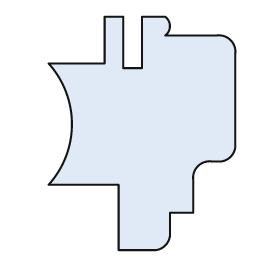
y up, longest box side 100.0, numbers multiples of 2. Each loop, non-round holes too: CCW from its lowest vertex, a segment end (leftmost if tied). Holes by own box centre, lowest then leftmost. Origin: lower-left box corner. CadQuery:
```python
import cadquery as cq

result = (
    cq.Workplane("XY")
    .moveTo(30.0, 0.0)
    .lineTo(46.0, 0.0)
    .threePointArc((50.0, 2.0), (52.0, 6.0))
    .lineTo(52.0, 16.0)
    .lineTo(62.0, 16.0)
    .lineTo(62.0, 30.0)
    .threePointArc((64.0, 36.0), (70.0, 38.0))
    .lineTo(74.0, 38.0)
    .threePointArc((78.0, 40.0), (80.0, 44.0))
    .lineTo(80.0, 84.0)
    .threePointArc((78.0, 90.0), (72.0, 92.0))
    .lineTo(50.0, 92.0)
    .threePointArc((52.0, 96.0), (50.0, 100.0))
    .lineTo(40.0, 100.0)
    .lineTo(40.0, 78.0)
    .lineTo(32.0, 78.0)
    .lineTo(32.0, 100.0)
    .lineTo(24.0, 100.0)
    .lineTo(24.0, 80.0)
    .lineTo(0.0, 80.0)
    .threePointArc((10.0, 54.0), (0.0, 28.0))
    .lineTo(30.0, 28.0)
    .close()
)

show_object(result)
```